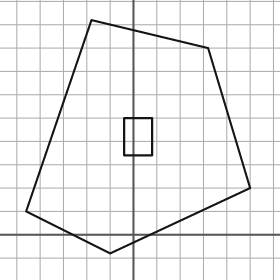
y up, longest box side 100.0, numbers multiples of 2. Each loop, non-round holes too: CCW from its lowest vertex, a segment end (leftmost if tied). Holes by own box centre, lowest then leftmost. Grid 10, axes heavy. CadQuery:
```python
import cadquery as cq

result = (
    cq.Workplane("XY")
    .moveTo(-10.0, -8.0)
    .lineTo(50.0, 20.0)
    .lineTo(32.0, 80.0)
    .lineTo(-18.0, 92.0)
    .lineTo(-46.0, 10.0)
    .close()
    .moveTo(-4.0, 34.0)
    .lineTo(8.0, 34.0)
    .lineTo(8.0, 50.0)
    .lineTo(-4.0, 50.0)
    .close()
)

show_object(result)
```